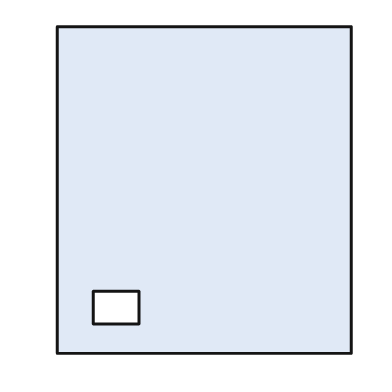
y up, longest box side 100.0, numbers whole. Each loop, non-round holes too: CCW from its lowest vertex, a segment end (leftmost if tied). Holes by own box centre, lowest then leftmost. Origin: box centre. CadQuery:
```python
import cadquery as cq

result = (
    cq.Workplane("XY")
    .moveTo(-45.0, -50.0)
    .lineTo(45.0, -50.0)
    .lineTo(45.0, 50.0)
    .lineTo(-45.0, 50.0)
    .close()
    .moveTo(-34.0, -41.0)
    .lineTo(-20.0, -41.0)
    .lineTo(-20.0, -31.0)
    .lineTo(-34.0, -31.0)
    .close()
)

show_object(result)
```